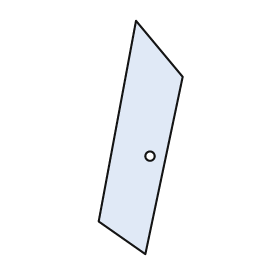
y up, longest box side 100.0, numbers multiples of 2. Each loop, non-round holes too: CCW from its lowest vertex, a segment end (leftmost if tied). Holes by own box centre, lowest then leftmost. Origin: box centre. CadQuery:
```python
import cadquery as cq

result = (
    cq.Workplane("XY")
    .moveTo(2.0, -50.0)
    .lineTo(18.0, 26.0)
    .lineTo(-2.0, 50.0)
    .lineTo(-18.0, -36.0)
    .close()
    .moveTo(4.0, -8.0)
    .circle(2.0)
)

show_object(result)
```